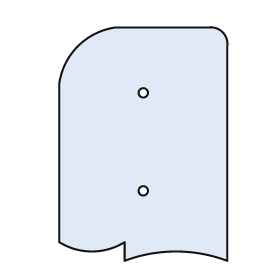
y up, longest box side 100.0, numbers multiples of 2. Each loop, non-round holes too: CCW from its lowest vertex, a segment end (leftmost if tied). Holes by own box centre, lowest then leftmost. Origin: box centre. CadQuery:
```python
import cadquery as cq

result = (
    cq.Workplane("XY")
    .moveTo(-8.0, -50.0)
    .threePointArc((14.0, -46.0), (36.0, -50.0))
    .lineTo(36.0, 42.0)
    .threePointArc((34.0, 48.0), (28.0, 50.0))
    .lineTo(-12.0, 50.0)
    .threePointArc((-28.0, 42.0), (-36.0, 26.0))
    .lineTo(-36.0, -42.0)
    .threePointArc((-22.0, -46.0), (-8.0, -42.0))
    .close()
    .moveTo(0.0, -20.0)
    .circle(2.0)
    .moveTo(0.0, 22.0)
    .circle(2.0)
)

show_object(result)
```